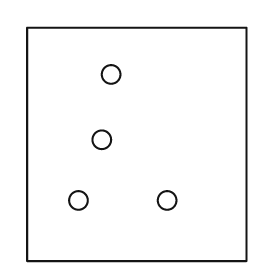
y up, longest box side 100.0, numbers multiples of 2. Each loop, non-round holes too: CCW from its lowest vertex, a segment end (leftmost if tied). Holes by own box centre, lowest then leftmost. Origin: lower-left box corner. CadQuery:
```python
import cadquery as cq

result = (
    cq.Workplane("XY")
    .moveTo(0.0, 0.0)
    .lineTo(94.0, 0.0)
    .lineTo(94.0, 100.0)
    .lineTo(0.0, 100.0)
    .close()
    .moveTo(22.0, 26.0)
    .circle(4.0)
    .moveTo(60.0, 26.0)
    .circle(4.0)
    .moveTo(32.0, 52.0)
    .circle(4.0)
    .moveTo(36.0, 80.0)
    .circle(4.0)
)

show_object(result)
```